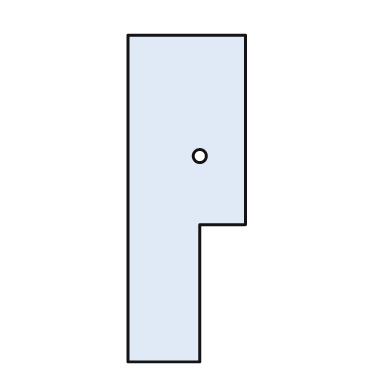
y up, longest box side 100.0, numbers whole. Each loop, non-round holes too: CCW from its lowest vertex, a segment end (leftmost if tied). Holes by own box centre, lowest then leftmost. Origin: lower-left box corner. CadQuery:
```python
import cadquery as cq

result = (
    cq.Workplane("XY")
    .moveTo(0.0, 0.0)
    .lineTo(22.0, 0.0)
    .lineTo(22.0, 42.0)
    .lineTo(36.0, 42.0)
    .lineTo(36.0, 100.0)
    .lineTo(0.0, 100.0)
    .close()
    .moveTo(22.0, 63.0)
    .circle(2.0)
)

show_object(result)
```